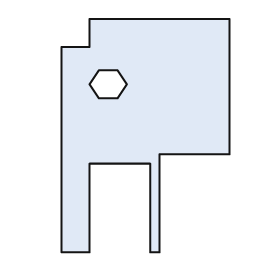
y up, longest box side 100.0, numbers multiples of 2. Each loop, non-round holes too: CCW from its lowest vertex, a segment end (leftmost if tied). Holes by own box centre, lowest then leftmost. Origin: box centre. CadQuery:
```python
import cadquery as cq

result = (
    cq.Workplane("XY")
    .moveTo(-36.0, -50.0)
    .lineTo(-24.0, -50.0)
    .lineTo(-24.0, -12.0)
    .lineTo(2.0, -12.0)
    .lineTo(2.0, -50.0)
    .lineTo(6.0, -50.0)
    .lineTo(6.0, -8.0)
    .lineTo(36.0, -8.0)
    .lineTo(36.0, 50.0)
    .lineTo(-24.0, 50.0)
    .lineTo(-24.0, 38.0)
    .lineTo(-36.0, 38.0)
    .close()
    .moveTo(-20.0, 16.0)
    .lineTo(-12.0, 16.0)
    .lineTo(-8.0, 22.0)
    .lineTo(-12.0, 28.0)
    .lineTo(-20.0, 28.0)
    .lineTo(-24.0, 22.0)
    .close()
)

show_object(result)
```